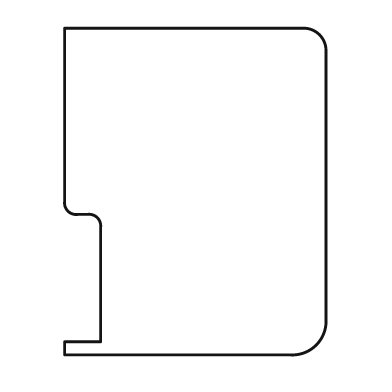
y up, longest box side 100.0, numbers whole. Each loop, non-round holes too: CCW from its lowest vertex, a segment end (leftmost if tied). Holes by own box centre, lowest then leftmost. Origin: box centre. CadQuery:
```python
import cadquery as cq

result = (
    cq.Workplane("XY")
    .moveTo(-40.0, -50.0)
    .lineTo(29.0, -50.0)
    .threePointArc((37.0, -47.0), (40.0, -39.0))
    .lineTo(40.0, 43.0)
    .threePointArc((38.0, 48.0), (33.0, 50.0))
    .lineTo(-40.0, 50.0)
    .lineTo(-40.0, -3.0)
    .threePointArc((-39.0, -6.0), (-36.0, -7.0))
    .lineTo(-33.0, -7.0)
    .threePointArc((-30.0, -8.0), (-29.0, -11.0))
    .lineTo(-29.0, -46.0)
    .lineTo(-40.0, -46.0)
    .close()
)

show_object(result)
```